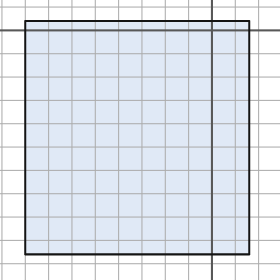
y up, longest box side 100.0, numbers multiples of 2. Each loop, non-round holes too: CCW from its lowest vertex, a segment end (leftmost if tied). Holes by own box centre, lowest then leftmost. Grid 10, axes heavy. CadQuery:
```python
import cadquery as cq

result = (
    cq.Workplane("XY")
    .moveTo(-80.0, -96.0)
    .lineTo(16.0, -96.0)
    .lineTo(16.0, 4.0)
    .lineTo(-80.0, 4.0)
    .close()
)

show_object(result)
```